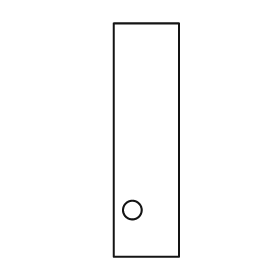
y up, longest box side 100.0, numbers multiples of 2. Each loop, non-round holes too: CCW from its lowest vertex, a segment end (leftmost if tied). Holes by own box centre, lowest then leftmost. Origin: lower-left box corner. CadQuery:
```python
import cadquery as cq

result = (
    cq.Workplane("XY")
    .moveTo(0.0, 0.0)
    .lineTo(28.0, 0.0)
    .lineTo(28.0, 100.0)
    .lineTo(0.0, 100.0)
    .close()
    .moveTo(8.0, 20.0)
    .circle(4.0)
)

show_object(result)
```